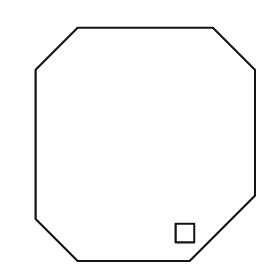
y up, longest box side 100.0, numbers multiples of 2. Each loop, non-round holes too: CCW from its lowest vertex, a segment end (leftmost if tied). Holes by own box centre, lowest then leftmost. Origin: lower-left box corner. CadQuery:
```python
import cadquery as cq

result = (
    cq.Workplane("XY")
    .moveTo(18.0, 0.0)
    .lineTo(66.0, 0.0)
    .lineTo(94.0, 28.0)
    .lineTo(94.0, 82.0)
    .lineTo(76.0, 100.0)
    .lineTo(18.0, 100.0)
    .lineTo(0.0, 82.0)
    .lineTo(0.0, 18.0)
    .close()
    .moveTo(60.0, 8.0)
    .lineTo(68.0, 8.0)
    .lineTo(68.0, 16.0)
    .lineTo(60.0, 16.0)
    .close()
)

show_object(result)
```